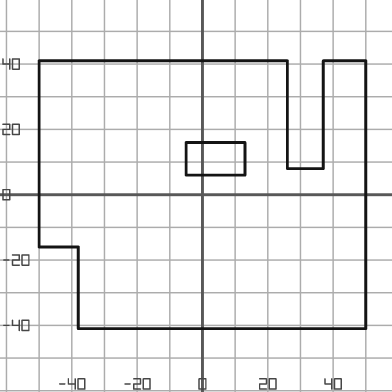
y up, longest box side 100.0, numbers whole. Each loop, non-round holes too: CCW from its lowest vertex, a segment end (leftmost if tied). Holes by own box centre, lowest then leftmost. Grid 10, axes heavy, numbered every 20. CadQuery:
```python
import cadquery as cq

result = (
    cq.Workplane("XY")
    .moveTo(-38.0, -41.0)
    .lineTo(50.0, -41.0)
    .lineTo(50.0, 41.0)
    .lineTo(37.0, 41.0)
    .lineTo(37.0, 8.0)
    .lineTo(26.0, 8.0)
    .lineTo(26.0, 41.0)
    .lineTo(-50.0, 41.0)
    .lineTo(-50.0, -16.0)
    .lineTo(-38.0, -16.0)
    .close()
    .moveTo(-5.0, 6.0)
    .lineTo(13.0, 6.0)
    .lineTo(13.0, 16.0)
    .lineTo(-5.0, 16.0)
    .close()
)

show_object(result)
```